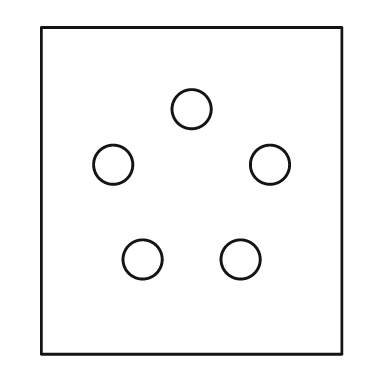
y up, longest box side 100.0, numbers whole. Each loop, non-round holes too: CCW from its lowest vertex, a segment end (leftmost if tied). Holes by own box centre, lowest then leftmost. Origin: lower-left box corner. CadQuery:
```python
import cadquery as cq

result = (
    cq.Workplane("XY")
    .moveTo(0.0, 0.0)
    .lineTo(92.0, 0.0)
    .lineTo(92.0, 100.0)
    .lineTo(0.0, 100.0)
    .close()
    .moveTo(31.0, 29.0)
    .circle(6.0)
    .moveTo(61.0, 29.0)
    .circle(6.0)
    .moveTo(22.0, 58.0)
    .circle(6.0)
    .moveTo(70.0, 58.0)
    .circle(6.0)
    .moveTo(46.0, 75.0)
    .circle(6.0)
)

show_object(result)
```